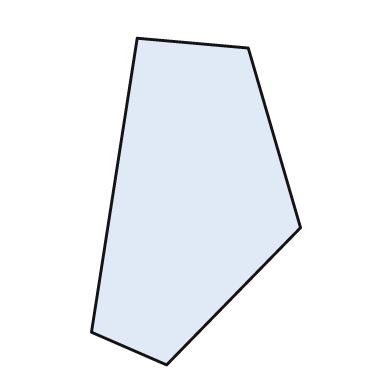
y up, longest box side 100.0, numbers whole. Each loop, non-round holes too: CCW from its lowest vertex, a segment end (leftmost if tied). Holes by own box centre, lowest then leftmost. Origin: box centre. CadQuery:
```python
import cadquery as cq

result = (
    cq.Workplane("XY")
    .moveTo(-9.0, -50.0)
    .lineTo(32.0, -8.0)
    .lineTo(16.0, 47.0)
    .lineTo(-18.0, 50.0)
    .lineTo(-32.0, -40.0)
    .close()
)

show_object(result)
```